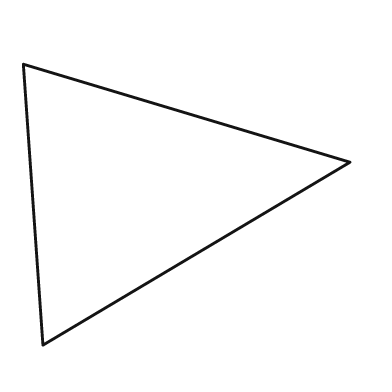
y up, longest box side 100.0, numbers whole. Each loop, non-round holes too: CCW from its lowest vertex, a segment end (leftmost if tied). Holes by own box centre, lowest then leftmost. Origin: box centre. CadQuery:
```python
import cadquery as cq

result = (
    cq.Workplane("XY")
    .moveTo(-44.0, -43.0)
    .lineTo(50.0, 13.0)
    .lineTo(-50.0, 43.0)
    .close()
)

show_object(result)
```